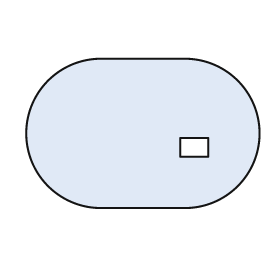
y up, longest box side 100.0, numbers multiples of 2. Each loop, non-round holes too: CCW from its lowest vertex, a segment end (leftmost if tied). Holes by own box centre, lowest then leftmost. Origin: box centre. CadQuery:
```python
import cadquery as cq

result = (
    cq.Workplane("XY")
    .moveTo(-18.0, -32.0)
    .lineTo(18.0, -32.0)
    .threePointArc((50.0, 0.0), (18.0, 32.0))
    .lineTo(-18.0, 32.0)
    .threePointArc((-50.0, 0.0), (-18.0, -32.0))
    .close()
    .moveTo(16.0, -10.0)
    .lineTo(28.0, -10.0)
    .lineTo(28.0, -2.0)
    .lineTo(16.0, -2.0)
    .close()
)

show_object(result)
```